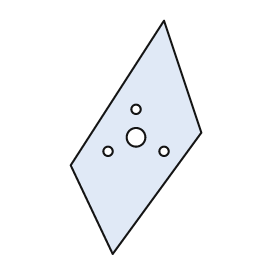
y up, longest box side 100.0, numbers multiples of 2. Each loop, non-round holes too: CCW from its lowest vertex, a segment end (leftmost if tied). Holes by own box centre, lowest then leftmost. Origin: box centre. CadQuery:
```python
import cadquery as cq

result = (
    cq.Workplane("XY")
    .moveTo(-10.0, -50.0)
    .lineTo(28.0, 2.0)
    .lineTo(12.0, 50.0)
    .lineTo(-28.0, -12.0)
    .close()
    .moveTo(-12.0, -6.0)
    .circle(2.0)
    .moveTo(12.0, -6.0)
    .circle(2.0)
    .moveTo(0.0, 0.0)
    .circle(4.0)
    .moveTo(0.0, 12.0)
    .circle(2.0)
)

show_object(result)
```